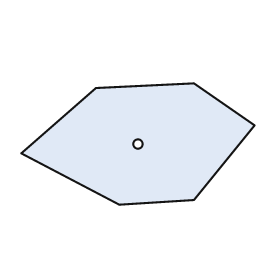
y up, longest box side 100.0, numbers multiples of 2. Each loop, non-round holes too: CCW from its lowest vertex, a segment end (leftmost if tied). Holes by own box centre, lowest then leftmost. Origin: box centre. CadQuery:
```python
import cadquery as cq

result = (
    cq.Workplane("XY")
    .moveTo(-8.0, -26.0)
    .lineTo(24.0, -24.0)
    .lineTo(50.0, 8.0)
    .lineTo(24.0, 26.0)
    .lineTo(-18.0, 24.0)
    .lineTo(-50.0, -4.0)
    .close()
    .moveTo(0.0, 0.0)
    .circle(2.0)
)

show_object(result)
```